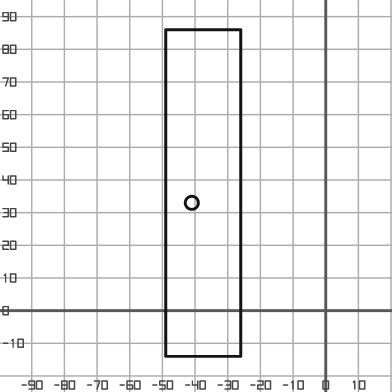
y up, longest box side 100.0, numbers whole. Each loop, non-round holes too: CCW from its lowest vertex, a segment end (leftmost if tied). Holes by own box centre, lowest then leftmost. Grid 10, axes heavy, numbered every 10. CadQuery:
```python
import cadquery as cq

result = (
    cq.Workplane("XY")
    .moveTo(-49.0, -14.0)
    .lineTo(-26.0, -14.0)
    .lineTo(-26.0, 86.0)
    .lineTo(-49.0, 86.0)
    .close()
    .moveTo(-41.0, 33.0)
    .circle(2.0)
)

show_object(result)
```